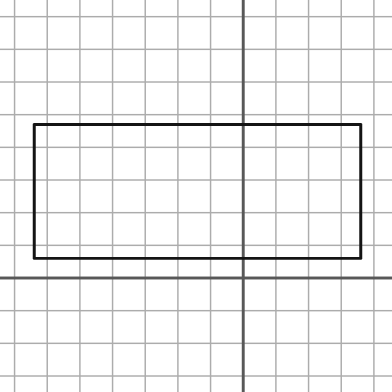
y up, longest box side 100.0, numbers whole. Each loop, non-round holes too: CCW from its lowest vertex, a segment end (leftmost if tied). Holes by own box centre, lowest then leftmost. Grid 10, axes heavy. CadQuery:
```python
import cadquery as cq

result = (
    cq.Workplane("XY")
    .moveTo(-64.0, 6.0)
    .lineTo(36.0, 6.0)
    .lineTo(36.0, 47.0)
    .lineTo(-64.0, 47.0)
    .close()
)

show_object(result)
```